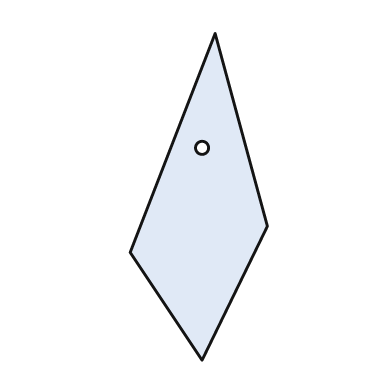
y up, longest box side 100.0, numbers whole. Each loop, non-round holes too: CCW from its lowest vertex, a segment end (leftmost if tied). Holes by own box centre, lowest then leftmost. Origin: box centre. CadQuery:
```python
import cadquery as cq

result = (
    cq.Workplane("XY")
    .moveTo(1.0, -50.0)
    .lineTo(21.0, -9.0)
    .lineTo(5.0, 50.0)
    .lineTo(-21.0, -17.0)
    .close()
    .moveTo(1.0, 15.0)
    .circle(2.0)
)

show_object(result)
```